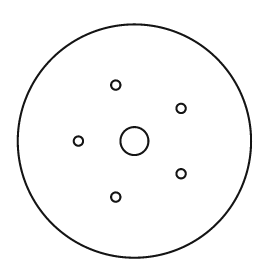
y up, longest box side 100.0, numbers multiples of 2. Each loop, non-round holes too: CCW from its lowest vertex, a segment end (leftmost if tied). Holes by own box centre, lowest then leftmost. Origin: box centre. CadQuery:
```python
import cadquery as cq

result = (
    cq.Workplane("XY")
    .moveTo(0.0, 0.0)
    .circle(50.0)
    .moveTo(-8.0, -24.0)
    .circle(2.0)
    .moveTo(20.0, -14.0)
    .circle(2.0)
    .moveTo(-24.0, 0.0)
    .circle(2.0)
    .moveTo(0.0, 0.0)
    .circle(6.0)
    .moveTo(20.0, 14.0)
    .circle(2.0)
    .moveTo(-8.0, 24.0)
    .circle(2.0)
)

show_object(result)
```